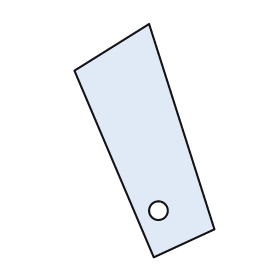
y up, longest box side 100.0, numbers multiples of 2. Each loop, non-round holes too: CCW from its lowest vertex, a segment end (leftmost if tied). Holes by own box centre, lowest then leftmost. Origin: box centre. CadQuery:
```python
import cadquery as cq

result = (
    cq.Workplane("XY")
    .moveTo(4.0, -50.0)
    .lineTo(30.0, -38.0)
    .lineTo(2.0, 50.0)
    .lineTo(-30.0, 30.0)
    .close()
    .moveTo(6.0, -30.0)
    .circle(4.0)
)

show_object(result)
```